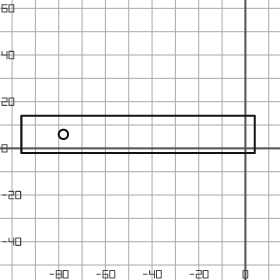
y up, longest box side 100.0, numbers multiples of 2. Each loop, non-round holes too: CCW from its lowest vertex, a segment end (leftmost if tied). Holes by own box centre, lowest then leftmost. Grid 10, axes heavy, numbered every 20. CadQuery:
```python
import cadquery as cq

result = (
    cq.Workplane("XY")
    .moveTo(-96.0, -2.0)
    .lineTo(4.0, -2.0)
    .lineTo(4.0, 14.0)
    .lineTo(-96.0, 14.0)
    .close()
    .moveTo(-78.0, 6.0)
    .circle(2.0)
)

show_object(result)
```